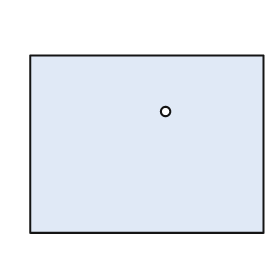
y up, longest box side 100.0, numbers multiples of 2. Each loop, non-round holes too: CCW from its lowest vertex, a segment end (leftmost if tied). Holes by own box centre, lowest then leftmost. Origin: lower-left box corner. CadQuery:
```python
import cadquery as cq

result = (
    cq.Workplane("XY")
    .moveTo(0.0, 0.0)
    .lineTo(100.0, 0.0)
    .lineTo(100.0, 76.0)
    .lineTo(0.0, 76.0)
    .close()
    .moveTo(58.0, 52.0)
    .circle(2.0)
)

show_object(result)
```